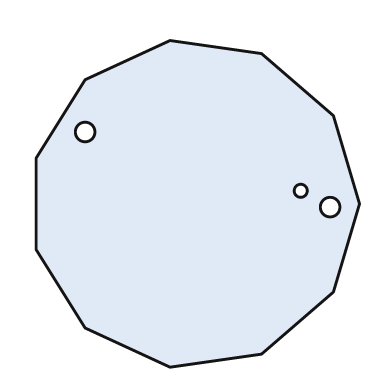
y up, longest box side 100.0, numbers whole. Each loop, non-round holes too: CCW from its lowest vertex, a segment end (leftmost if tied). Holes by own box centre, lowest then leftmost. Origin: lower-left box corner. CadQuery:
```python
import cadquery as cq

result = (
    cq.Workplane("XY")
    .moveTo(41.0, 0.0)
    .lineTo(69.0, 4.0)
    .lineTo(91.0, 23.0)
    .lineTo(99.0, 50.0)
    .lineTo(91.0, 77.0)
    .lineTo(69.0, 96.0)
    .lineTo(41.0, 100.0)
    .lineTo(15.0, 88.0)
    .lineTo(0.0, 64.0)
    .lineTo(0.0, 36.0)
    .lineTo(15.0, 12.0)
    .close()
    .moveTo(90.0, 49.0)
    .circle(3.0)
    .moveTo(81.0, 54.0)
    .circle(2.0)
    .moveTo(15.0, 72.0)
    .circle(3.0)
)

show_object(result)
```